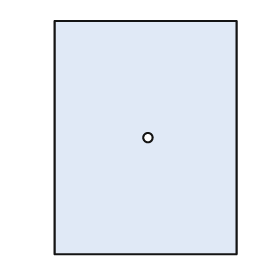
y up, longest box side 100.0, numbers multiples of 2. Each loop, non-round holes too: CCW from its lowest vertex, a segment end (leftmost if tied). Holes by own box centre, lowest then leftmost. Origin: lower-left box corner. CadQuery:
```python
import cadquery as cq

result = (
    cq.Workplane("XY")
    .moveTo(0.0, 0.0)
    .lineTo(78.0, 0.0)
    .lineTo(78.0, 100.0)
    .lineTo(0.0, 100.0)
    .close()
    .moveTo(40.0, 50.0)
    .circle(2.0)
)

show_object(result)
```